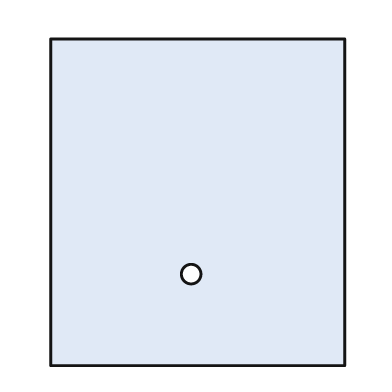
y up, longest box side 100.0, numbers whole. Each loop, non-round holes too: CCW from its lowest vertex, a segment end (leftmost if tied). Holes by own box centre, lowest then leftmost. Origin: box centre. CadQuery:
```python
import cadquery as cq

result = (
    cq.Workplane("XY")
    .moveTo(-45.0, -50.0)
    .lineTo(45.0, -50.0)
    .lineTo(45.0, 50.0)
    .lineTo(-45.0, 50.0)
    .close()
    .moveTo(-2.0, -22.0)
    .circle(3.0)
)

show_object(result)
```